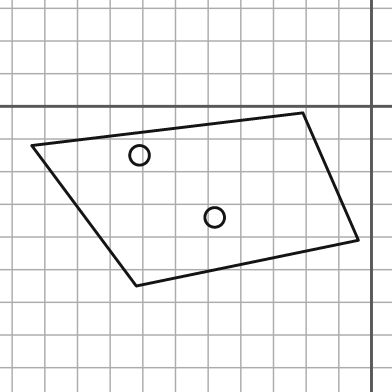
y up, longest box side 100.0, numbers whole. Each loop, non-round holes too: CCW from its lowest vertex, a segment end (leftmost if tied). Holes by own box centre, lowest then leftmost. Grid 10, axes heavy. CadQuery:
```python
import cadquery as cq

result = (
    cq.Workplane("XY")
    .moveTo(-72.0, -55.0)
    .lineTo(-4.0, -41.0)
    .lineTo(-21.0, -2.0)
    .lineTo(-104.0, -12.0)
    .close()
    .moveTo(-48.0, -34.0)
    .circle(3.0)
    .moveTo(-71.0, -15.0)
    .circle(3.0)
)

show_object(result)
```